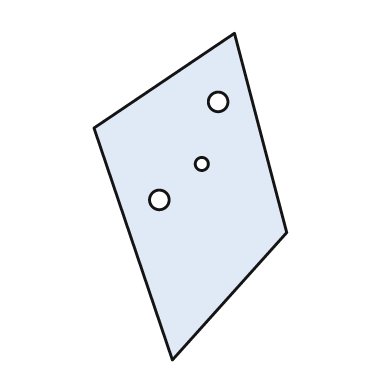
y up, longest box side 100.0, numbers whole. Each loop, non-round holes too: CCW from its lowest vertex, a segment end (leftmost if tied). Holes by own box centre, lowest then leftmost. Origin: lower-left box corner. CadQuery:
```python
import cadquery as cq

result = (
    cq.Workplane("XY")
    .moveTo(24.0, 0.0)
    .lineTo(59.0, 39.0)
    .lineTo(43.0, 100.0)
    .lineTo(0.0, 71.0)
    .close()
    .moveTo(20.0, 49.0)
    .circle(3.0)
    .moveTo(33.0, 60.0)
    .circle(2.0)
    .moveTo(38.0, 79.0)
    .circle(3.0)
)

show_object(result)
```